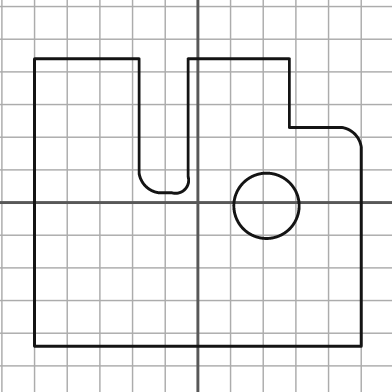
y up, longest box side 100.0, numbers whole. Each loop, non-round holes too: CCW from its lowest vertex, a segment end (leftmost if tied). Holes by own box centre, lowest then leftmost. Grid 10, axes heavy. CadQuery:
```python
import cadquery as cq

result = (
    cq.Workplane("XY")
    .moveTo(-50.0, -44.0)
    .lineTo(50.0, -44.0)
    .lineTo(50.0, 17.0)
    .threePointArc((48.0, 21.0), (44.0, 23.0))
    .lineTo(28.0, 23.0)
    .lineTo(28.0, 44.0)
    .lineTo(-3.0, 44.0)
    .lineTo(-3.0, 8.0)
    .threePointArc((-4.0, 4.0), (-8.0, 3.0))
    .lineTo(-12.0, 3.0)
    .threePointArc((-16.0, 5.0), (-18.0, 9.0))
    .lineTo(-18.0, 44.0)
    .lineTo(-50.0, 44.0)
    .close()
    .moveTo(21.0, -1.0)
    .circle(10.0)
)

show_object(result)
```